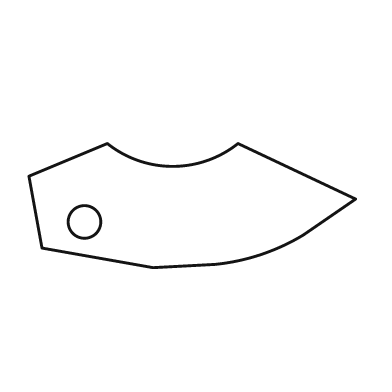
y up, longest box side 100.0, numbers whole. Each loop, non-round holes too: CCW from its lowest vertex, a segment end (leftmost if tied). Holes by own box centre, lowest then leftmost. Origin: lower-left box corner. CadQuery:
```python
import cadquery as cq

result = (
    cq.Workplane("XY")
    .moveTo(38.0, 0.0)
    .lineTo(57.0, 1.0)
    .threePointArc((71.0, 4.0), (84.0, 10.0))
    .lineTo(100.0, 21.0)
    .lineTo(64.0, 38.0)
    .threePointArc((44.0, 31.0), (24.0, 38.0))
    .lineTo(0.0, 28.0)
    .lineTo(4.0, 6.0)
    .close()
    .moveTo(17.0, 14.0)
    .circle(5.0)
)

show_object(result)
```